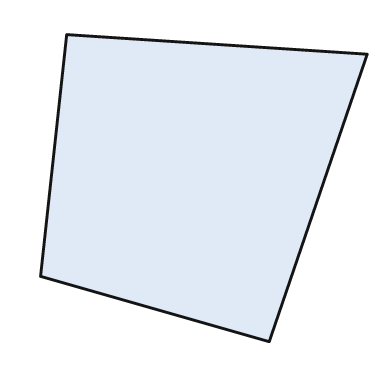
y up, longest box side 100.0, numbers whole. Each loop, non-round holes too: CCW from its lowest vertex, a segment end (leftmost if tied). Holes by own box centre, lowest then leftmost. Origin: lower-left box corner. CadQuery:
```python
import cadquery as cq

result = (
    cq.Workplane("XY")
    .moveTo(70.0, 0.0)
    .lineTo(100.0, 88.0)
    .lineTo(8.0, 94.0)
    .lineTo(0.0, 20.0)
    .close()
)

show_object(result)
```